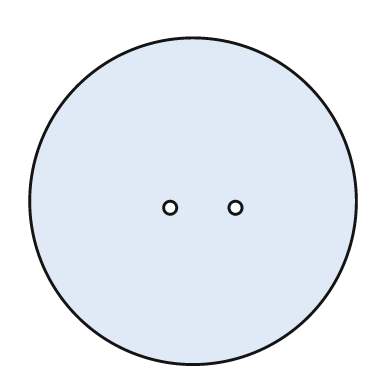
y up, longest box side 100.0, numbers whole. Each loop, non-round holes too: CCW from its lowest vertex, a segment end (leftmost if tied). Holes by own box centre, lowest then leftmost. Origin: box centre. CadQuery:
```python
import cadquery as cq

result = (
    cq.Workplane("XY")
    .moveTo(0.0, 0.0)
    .circle(50.0)
    .moveTo(-7.0, -2.0)
    .circle(2.0)
    .moveTo(13.0, -2.0)
    .circle(2.0)
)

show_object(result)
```